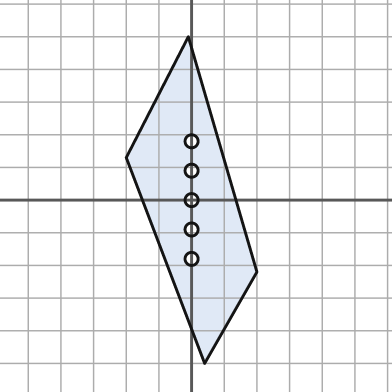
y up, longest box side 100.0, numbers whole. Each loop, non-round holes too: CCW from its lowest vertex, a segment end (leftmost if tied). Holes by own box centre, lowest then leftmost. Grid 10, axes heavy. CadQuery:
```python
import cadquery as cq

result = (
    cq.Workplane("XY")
    .moveTo(4.0, -50.0)
    .lineTo(20.0, -22.0)
    .lineTo(-1.0, 50.0)
    .lineTo(-20.0, 13.0)
    .close()
    .moveTo(0.0, -18.0)
    .circle(2.0)
    .moveTo(0.0, -9.0)
    .circle(2.0)
    .moveTo(0.0, 0.0)
    .circle(2.0)
    .moveTo(0.0, 9.0)
    .circle(2.0)
    .moveTo(0.0, 18.0)
    .circle(2.0)
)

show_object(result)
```